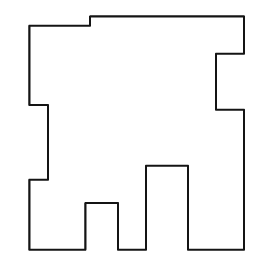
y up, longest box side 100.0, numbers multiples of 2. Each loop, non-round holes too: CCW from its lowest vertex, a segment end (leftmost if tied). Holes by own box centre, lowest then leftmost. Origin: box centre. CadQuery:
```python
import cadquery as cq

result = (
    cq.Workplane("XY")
    .moveTo(-46.0, -50.0)
    .lineTo(-22.0, -50.0)
    .lineTo(-22.0, -30.0)
    .lineTo(-8.0, -30.0)
    .lineTo(-8.0, -50.0)
    .lineTo(4.0, -50.0)
    .lineTo(4.0, -14.0)
    .lineTo(22.0, -14.0)
    .lineTo(22.0, -50.0)
    .lineTo(46.0, -50.0)
    .lineTo(46.0, 10.0)
    .lineTo(34.0, 10.0)
    .lineTo(34.0, 34.0)
    .lineTo(46.0, 34.0)
    .lineTo(46.0, 50.0)
    .lineTo(-20.0, 50.0)
    .lineTo(-20.0, 46.0)
    .lineTo(-46.0, 46.0)
    .lineTo(-46.0, 12.0)
    .lineTo(-38.0, 12.0)
    .lineTo(-38.0, -20.0)
    .lineTo(-46.0, -20.0)
    .close()
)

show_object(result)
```